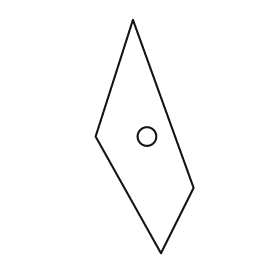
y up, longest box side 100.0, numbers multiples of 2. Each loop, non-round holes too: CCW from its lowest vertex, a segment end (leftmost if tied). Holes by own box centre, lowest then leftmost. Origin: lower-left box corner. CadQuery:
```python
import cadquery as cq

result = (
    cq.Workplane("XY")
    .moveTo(28.0, 0.0)
    .lineTo(42.0, 28.0)
    .lineTo(16.0, 100.0)
    .lineTo(0.0, 50.0)
    .close()
    .moveTo(22.0, 50.0)
    .circle(4.0)
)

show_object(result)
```